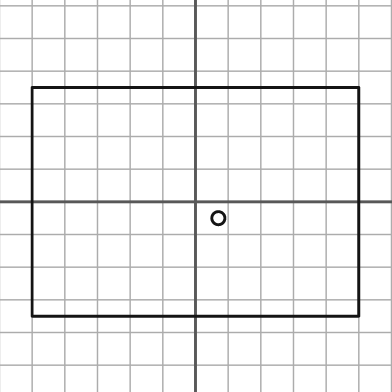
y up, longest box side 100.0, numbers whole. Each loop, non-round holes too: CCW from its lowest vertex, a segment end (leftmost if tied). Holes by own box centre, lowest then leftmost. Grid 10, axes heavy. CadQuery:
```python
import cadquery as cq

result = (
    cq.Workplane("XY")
    .moveTo(-50.0, -35.0)
    .lineTo(50.0, -35.0)
    .lineTo(50.0, 35.0)
    .lineTo(-50.0, 35.0)
    .close()
    .moveTo(7.0, -5.0)
    .circle(2.0)
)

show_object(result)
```